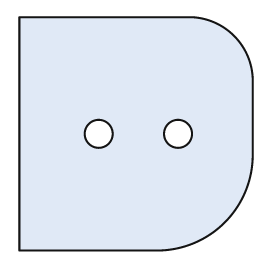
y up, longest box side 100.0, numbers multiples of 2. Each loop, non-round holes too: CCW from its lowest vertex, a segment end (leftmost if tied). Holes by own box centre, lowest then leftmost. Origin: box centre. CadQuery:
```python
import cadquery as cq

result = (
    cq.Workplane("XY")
    .moveTo(-50.0, -50.0)
    .lineTo(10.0, -50.0)
    .threePointArc((38.0, -38.0), (50.0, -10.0))
    .lineTo(50.0, 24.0)
    .threePointArc((42.0, 42.0), (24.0, 50.0))
    .lineTo(-50.0, 50.0)
    .close()
    .moveTo(-16.0, 0.0)
    .circle(6.0)
    .moveTo(18.0, 0.0)
    .circle(6.0)
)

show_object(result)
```